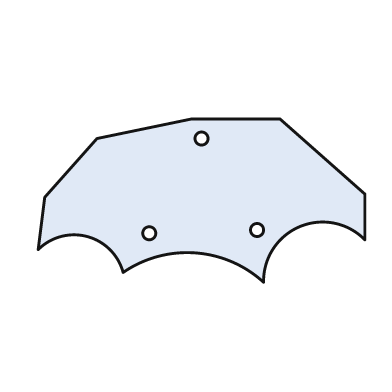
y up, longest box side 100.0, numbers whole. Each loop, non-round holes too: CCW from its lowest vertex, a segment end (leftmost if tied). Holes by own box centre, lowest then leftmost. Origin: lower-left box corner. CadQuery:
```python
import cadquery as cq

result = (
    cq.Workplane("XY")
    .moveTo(69.0, 0.0)
    .threePointArc((80.0, 17.0), (100.0, 13.0))
    .lineTo(100.0, 27.0)
    .lineTo(74.0, 50.0)
    .lineTo(47.0, 50.0)
    .lineTo(18.0, 44.0)
    .lineTo(2.0, 26.0)
    .lineTo(0.0, 10.0)
    .threePointArc((15.0, 14.0), (26.0, 3.0))
    .threePointArc((48.0, 9.0), (69.0, 0.0))
    .close()
    .moveTo(34.0, 15.0)
    .circle(2.0)
    .moveTo(67.0, 16.0)
    .circle(2.0)
    .moveTo(50.0, 44.0)
    .circle(2.0)
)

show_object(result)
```